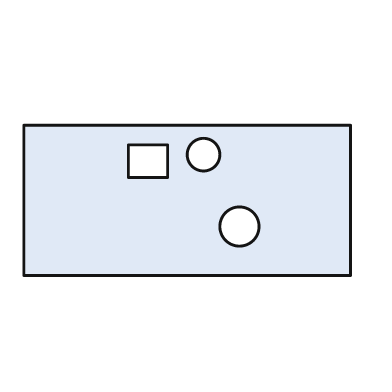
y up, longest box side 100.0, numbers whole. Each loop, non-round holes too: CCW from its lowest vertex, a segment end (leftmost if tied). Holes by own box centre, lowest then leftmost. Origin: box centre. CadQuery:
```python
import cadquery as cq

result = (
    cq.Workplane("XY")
    .moveTo(-50.0, -23.0)
    .lineTo(50.0, -23.0)
    .lineTo(50.0, 23.0)
    .lineTo(-50.0, 23.0)
    .close()
    .moveTo(16.0, -8.0)
    .circle(6.0)
    .moveTo(-18.0, 7.0)
    .lineTo(-6.0, 7.0)
    .lineTo(-6.0, 17.0)
    .lineTo(-18.0, 17.0)
    .close()
    .moveTo(5.0, 14.0)
    .circle(5.0)
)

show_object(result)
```